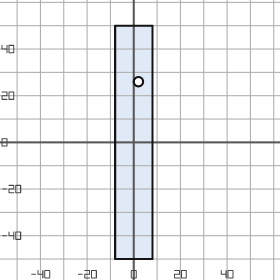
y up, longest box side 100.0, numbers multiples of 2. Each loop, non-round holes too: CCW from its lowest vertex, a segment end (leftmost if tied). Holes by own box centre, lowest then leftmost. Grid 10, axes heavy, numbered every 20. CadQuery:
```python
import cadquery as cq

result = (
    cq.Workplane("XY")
    .moveTo(-8.0, -50.0)
    .lineTo(8.0, -50.0)
    .lineTo(8.0, 50.0)
    .lineTo(-8.0, 50.0)
    .close()
    .moveTo(2.0, 26.0)
    .circle(2.0)
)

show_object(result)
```